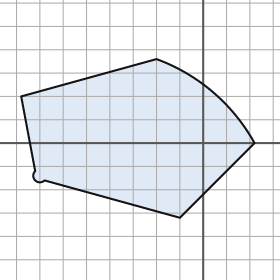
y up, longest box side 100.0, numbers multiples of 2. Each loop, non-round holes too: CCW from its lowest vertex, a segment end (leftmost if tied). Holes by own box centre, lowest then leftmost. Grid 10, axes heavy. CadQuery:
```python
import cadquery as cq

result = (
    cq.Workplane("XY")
    .moveTo(-10.0, -32.0)
    .lineTo(22.0, 0.0)
    .threePointArc((4.0, 22.0), (-20.0, 36.0))
    .lineTo(-78.0, 20.0)
    .lineTo(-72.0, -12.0)
    .threePointArc((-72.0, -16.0), (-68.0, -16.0))
    .close()
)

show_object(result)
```